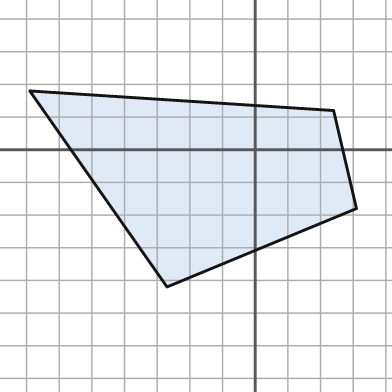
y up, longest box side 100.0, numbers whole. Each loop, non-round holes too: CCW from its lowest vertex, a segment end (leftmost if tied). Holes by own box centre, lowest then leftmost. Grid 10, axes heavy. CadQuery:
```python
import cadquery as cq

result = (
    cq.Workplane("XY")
    .moveTo(-27.0, -42.0)
    .lineTo(31.0, -18.0)
    .lineTo(24.0, 12.0)
    .lineTo(-69.0, 18.0)
    .close()
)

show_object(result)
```